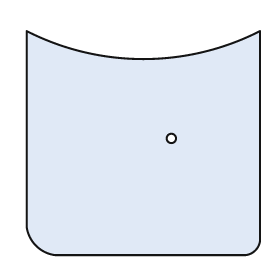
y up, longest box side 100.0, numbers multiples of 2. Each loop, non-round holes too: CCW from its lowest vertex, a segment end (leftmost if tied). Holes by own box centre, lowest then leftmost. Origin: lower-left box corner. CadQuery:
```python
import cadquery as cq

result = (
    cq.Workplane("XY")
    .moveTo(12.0, 0.0)
    .lineTo(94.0, 0.0)
    .threePointArc((98.0, 2.0), (100.0, 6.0))
    .lineTo(100.0, 96.0)
    .threePointArc((50.0, 84.0), (0.0, 96.0))
    .lineTo(0.0, 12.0)
    .threePointArc((4.0, 4.0), (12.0, 0.0))
    .close()
    .moveTo(62.0, 50.0)
    .circle(2.0)
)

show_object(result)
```